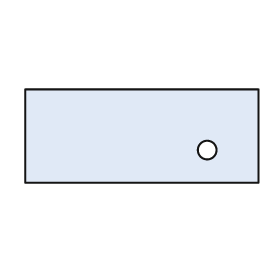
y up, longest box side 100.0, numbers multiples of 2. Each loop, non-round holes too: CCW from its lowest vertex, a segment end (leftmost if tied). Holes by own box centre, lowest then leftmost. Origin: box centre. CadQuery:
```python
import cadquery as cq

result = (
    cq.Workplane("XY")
    .moveTo(-50.0, -20.0)
    .lineTo(50.0, -20.0)
    .lineTo(50.0, 20.0)
    .lineTo(-50.0, 20.0)
    .close()
    .moveTo(28.0, -6.0)
    .circle(4.0)
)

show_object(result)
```